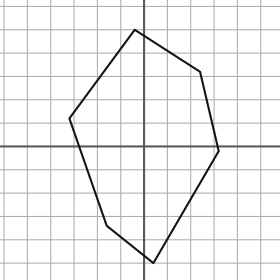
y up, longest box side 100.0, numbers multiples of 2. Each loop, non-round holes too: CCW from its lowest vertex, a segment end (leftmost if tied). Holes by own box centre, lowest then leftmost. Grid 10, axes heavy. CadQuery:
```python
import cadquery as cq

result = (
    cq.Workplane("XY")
    .moveTo(4.0, -50.0)
    .lineTo(32.0, -2.0)
    .lineTo(24.0, 32.0)
    .lineTo(-4.0, 50.0)
    .lineTo(-32.0, 12.0)
    .lineTo(-16.0, -34.0)
    .close()
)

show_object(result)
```